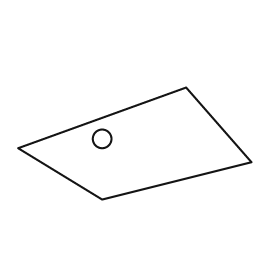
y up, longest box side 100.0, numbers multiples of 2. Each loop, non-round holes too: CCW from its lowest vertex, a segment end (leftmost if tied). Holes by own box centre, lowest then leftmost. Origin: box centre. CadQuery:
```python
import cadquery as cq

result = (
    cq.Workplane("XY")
    .moveTo(-14.0, -24.0)
    .lineTo(50.0, -8.0)
    .lineTo(22.0, 24.0)
    .lineTo(-50.0, -2.0)
    .close()
    .moveTo(-14.0, 2.0)
    .circle(4.0)
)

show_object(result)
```